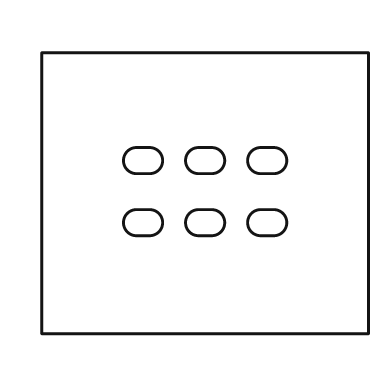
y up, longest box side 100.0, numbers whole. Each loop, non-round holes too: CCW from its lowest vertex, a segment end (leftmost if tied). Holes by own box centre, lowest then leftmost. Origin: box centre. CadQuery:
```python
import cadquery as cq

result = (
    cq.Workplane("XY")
    .moveTo(-50.0, -43.0)
    .lineTo(50.0, -43.0)
    .lineTo(50.0, 43.0)
    .lineTo(-50.0, 43.0)
    .close()
    .moveTo(-21.0, -13.0)
    .lineTo(-17.0, -13.0)
    .threePointArc((-13.0, -9.0), (-17.0, -5.0))
    .lineTo(-21.0, -5.0)
    .threePointArc((-25.0, -9.0), (-21.0, -13.0))
    .close()
    .moveTo(-2.0, -13.0)
    .lineTo(2.0, -13.0)
    .threePointArc((6.0, -9.0), (2.0, -5.0))
    .lineTo(-2.0, -5.0)
    .threePointArc((-6.0, -9.0), (-2.0, -13.0))
    .close()
    .moveTo(17.0, -13.0)
    .lineTo(21.0, -13.0)
    .threePointArc((25.0, -9.0), (21.0, -5.0))
    .lineTo(17.0, -5.0)
    .threePointArc((13.0, -9.0), (17.0, -13.0))
    .close()
    .moveTo(-21.0, 6.0)
    .lineTo(-17.0, 6.0)
    .threePointArc((-13.0, 10.0), (-17.0, 14.0))
    .lineTo(-21.0, 14.0)
    .threePointArc((-25.0, 10.0), (-21.0, 6.0))
    .close()
    .moveTo(-2.0, 6.0)
    .lineTo(2.0, 6.0)
    .threePointArc((6.0, 10.0), (2.0, 14.0))
    .lineTo(-2.0, 14.0)
    .threePointArc((-6.0, 10.0), (-2.0, 6.0))
    .close()
    .moveTo(17.0, 6.0)
    .lineTo(21.0, 6.0)
    .threePointArc((25.0, 10.0), (21.0, 14.0))
    .lineTo(17.0, 14.0)
    .threePointArc((13.0, 10.0), (17.0, 6.0))
    .close()
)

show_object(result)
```